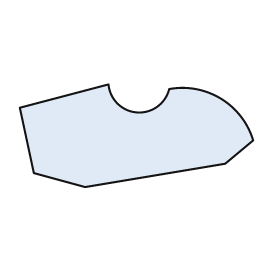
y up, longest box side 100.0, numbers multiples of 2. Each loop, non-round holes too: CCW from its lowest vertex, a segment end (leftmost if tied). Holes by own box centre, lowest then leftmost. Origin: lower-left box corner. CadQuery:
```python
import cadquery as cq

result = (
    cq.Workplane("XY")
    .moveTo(28.0, 0.0)
    .lineTo(88.0, 10.0)
    .lineTo(100.0, 20.0)
    .threePointArc((86.0, 38.0), (64.0, 42.0))
    .threePointArc((50.0, 32.0), (38.0, 44.0))
    .lineTo(0.0, 34.0)
    .lineTo(6.0, 6.0)
    .close()
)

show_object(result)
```